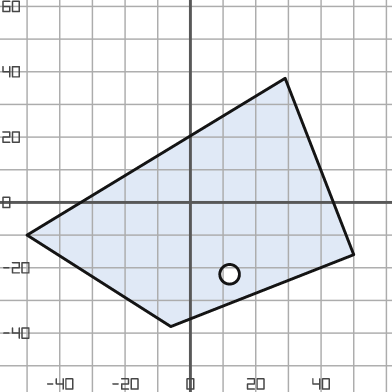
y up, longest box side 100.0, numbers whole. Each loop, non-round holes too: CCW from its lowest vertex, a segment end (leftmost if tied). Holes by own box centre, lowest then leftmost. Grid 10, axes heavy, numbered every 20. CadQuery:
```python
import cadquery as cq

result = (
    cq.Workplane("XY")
    .moveTo(-6.0, -38.0)
    .lineTo(50.0, -16.0)
    .lineTo(29.0, 38.0)
    .lineTo(-50.0, -10.0)
    .close()
    .moveTo(12.0, -22.0)
    .circle(3.0)
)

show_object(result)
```